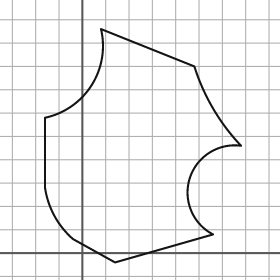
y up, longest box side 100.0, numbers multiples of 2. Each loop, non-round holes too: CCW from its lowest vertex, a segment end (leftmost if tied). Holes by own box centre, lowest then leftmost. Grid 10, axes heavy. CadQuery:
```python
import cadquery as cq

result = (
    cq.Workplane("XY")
    .moveTo(14.0, -4.0)
    .lineTo(56.0, 8.0)
    .threePointArc((46.0, 32.0), (68.0, 46.0))
    .threePointArc((56.0, 62.0), (48.0, 80.0))
    .lineTo(8.0, 96.0)
    .threePointArc((4.0, 72.0), (-16.0, 58.0))
    .lineTo(-16.0, 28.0)
    .threePointArc((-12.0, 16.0), (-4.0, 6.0))
    .close()
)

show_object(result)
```